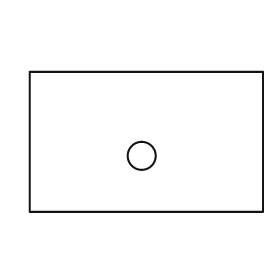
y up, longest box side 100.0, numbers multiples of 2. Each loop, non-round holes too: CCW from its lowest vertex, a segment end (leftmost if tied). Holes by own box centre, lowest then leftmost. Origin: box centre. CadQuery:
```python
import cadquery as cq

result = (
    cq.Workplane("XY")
    .moveTo(-50.0, -30.0)
    .lineTo(50.0, -30.0)
    .lineTo(50.0, 30.0)
    .lineTo(-50.0, 30.0)
    .close()
    .moveTo(-2.0, -6.0)
    .circle(6.0)
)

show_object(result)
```